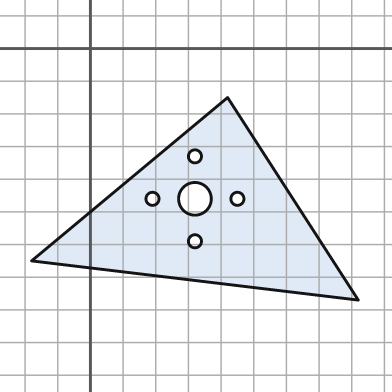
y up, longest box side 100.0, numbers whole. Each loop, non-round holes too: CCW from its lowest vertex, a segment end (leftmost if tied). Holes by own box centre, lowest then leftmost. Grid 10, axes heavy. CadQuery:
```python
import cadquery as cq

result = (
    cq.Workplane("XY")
    .moveTo(82.0, -77.0)
    .lineTo(42.0, -15.0)
    .lineTo(-18.0, -65.0)
    .close()
    .moveTo(32.0, -59.0)
    .circle(2.0)
    .moveTo(19.0, -46.0)
    .circle(2.0)
    .moveTo(32.0, -46.0)
    .circle(5.0)
    .moveTo(45.0, -46.0)
    .circle(2.0)
    .moveTo(32.0, -33.0)
    .circle(2.0)
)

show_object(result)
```